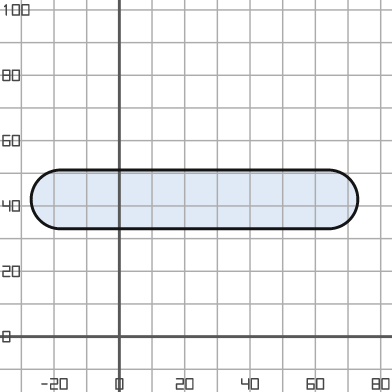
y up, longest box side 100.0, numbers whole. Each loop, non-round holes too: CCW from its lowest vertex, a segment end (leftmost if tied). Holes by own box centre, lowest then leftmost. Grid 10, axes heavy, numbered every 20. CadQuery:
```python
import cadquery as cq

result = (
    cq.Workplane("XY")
    .moveTo(-18.0, 33.0)
    .lineTo(64.0, 33.0)
    .threePointArc((73.0, 42.0), (64.0, 51.0))
    .lineTo(-18.0, 51.0)
    .threePointArc((-27.0, 42.0), (-18.0, 33.0))
    .close()
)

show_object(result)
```